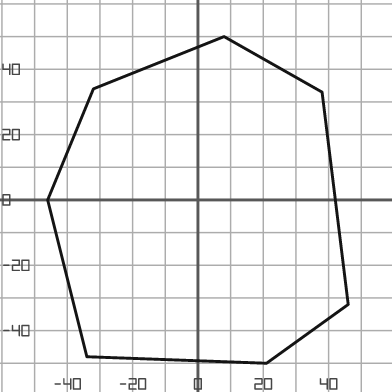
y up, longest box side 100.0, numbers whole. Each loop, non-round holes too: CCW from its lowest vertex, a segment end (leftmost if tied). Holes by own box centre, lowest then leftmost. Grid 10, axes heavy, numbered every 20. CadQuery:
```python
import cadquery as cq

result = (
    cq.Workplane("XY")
    .moveTo(21.0, -50.0)
    .lineTo(46.0, -32.0)
    .lineTo(38.0, 33.0)
    .lineTo(8.0, 50.0)
    .lineTo(-32.0, 34.0)
    .lineTo(-46.0, 0.0)
    .lineTo(-34.0, -48.0)
    .close()
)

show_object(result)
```